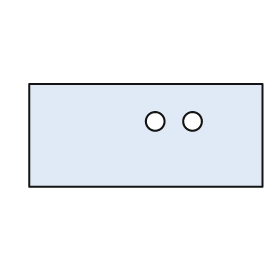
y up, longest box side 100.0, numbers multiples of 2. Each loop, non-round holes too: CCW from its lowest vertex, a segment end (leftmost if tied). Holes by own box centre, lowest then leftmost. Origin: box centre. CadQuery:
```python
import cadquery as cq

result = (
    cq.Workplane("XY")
    .moveTo(-50.0, -22.0)
    .lineTo(50.0, -22.0)
    .lineTo(50.0, 22.0)
    .lineTo(-50.0, 22.0)
    .close()
    .moveTo(4.0, 6.0)
    .circle(4.0)
    .moveTo(20.0, 6.0)
    .circle(4.0)
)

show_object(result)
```